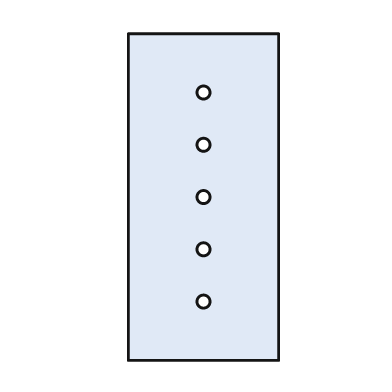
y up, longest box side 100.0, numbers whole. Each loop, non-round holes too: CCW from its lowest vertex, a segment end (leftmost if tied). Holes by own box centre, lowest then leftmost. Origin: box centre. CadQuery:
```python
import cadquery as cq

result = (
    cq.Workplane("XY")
    .moveTo(-23.0, -50.0)
    .lineTo(23.0, -50.0)
    .lineTo(23.0, 50.0)
    .lineTo(-23.0, 50.0)
    .close()
    .moveTo(0.0, -32.0)
    .circle(2.0)
    .moveTo(0.0, -16.0)
    .circle(2.0)
    .moveTo(0.0, 0.0)
    .circle(2.0)
    .moveTo(0.0, 16.0)
    .circle(2.0)
    .moveTo(0.0, 32.0)
    .circle(2.0)
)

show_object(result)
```